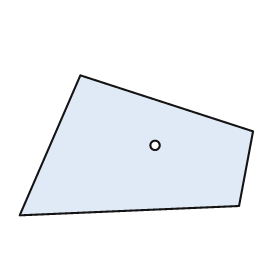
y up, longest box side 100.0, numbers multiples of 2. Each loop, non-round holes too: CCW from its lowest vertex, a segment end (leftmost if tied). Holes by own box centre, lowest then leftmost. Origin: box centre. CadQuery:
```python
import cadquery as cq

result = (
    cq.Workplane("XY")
    .moveTo(-50.0, -30.0)
    .lineTo(44.0, -26.0)
    .lineTo(50.0, 6.0)
    .lineTo(-24.0, 30.0)
    .close()
    .moveTo(8.0, 0.0)
    .circle(2.0)
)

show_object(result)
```